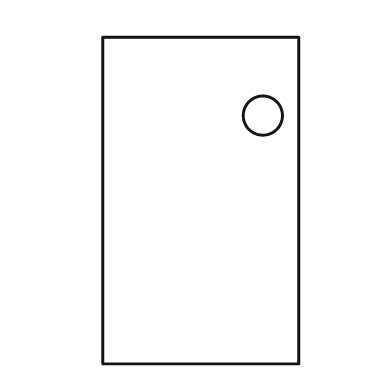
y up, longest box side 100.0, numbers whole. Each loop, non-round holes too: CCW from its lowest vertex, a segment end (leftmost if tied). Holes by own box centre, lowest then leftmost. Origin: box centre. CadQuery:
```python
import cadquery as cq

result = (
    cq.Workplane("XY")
    .moveTo(-30.0, -50.0)
    .lineTo(30.0, -50.0)
    .lineTo(30.0, 50.0)
    .lineTo(-30.0, 50.0)
    .close()
    .moveTo(19.0, 26.0)
    .circle(6.0)
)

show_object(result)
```